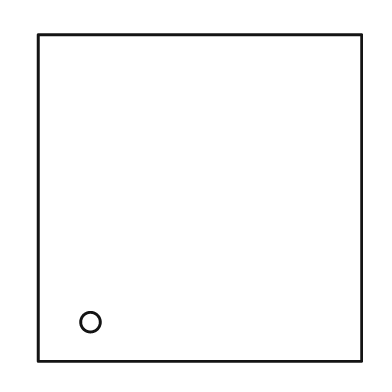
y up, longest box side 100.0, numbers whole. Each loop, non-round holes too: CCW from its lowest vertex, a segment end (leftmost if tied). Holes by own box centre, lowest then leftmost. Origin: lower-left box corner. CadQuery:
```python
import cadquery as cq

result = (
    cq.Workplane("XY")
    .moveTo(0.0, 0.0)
    .lineTo(99.0, 0.0)
    .lineTo(99.0, 100.0)
    .lineTo(0.0, 100.0)
    .close()
    .moveTo(16.0, 12.0)
    .circle(3.0)
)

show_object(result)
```